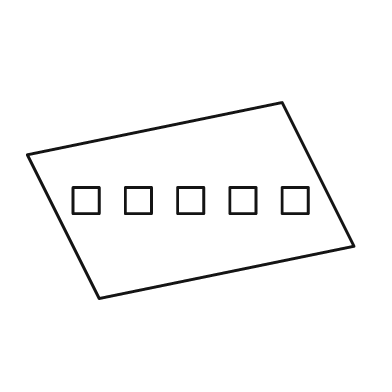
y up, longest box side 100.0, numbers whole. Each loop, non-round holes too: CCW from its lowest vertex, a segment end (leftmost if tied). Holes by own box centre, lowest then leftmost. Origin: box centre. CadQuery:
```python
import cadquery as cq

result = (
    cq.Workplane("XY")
    .moveTo(-28.0, -30.0)
    .lineTo(50.0, -14.0)
    .lineTo(28.0, 30.0)
    .lineTo(-50.0, 14.0)
    .close()
    .moveTo(-36.0, -4.0)
    .lineTo(-28.0, -4.0)
    .lineTo(-28.0, 4.0)
    .lineTo(-36.0, 4.0)
    .close()
    .moveTo(-20.0, -4.0)
    .lineTo(-12.0, -4.0)
    .lineTo(-12.0, 4.0)
    .lineTo(-20.0, 4.0)
    .close()
    .moveTo(-4.0, -4.0)
    .lineTo(4.0, -4.0)
    .lineTo(4.0, 4.0)
    .lineTo(-4.0, 4.0)
    .close()
    .moveTo(12.0, -4.0)
    .lineTo(20.0, -4.0)
    .lineTo(20.0, 4.0)
    .lineTo(12.0, 4.0)
    .close()
    .moveTo(28.0, -4.0)
    .lineTo(36.0, -4.0)
    .lineTo(36.0, 4.0)
    .lineTo(28.0, 4.0)
    .close()
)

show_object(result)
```